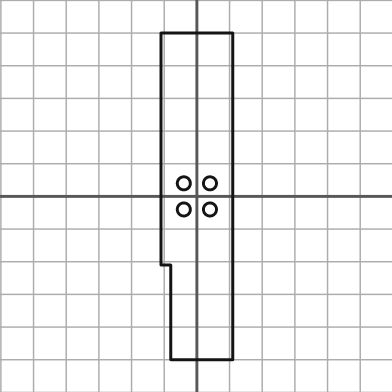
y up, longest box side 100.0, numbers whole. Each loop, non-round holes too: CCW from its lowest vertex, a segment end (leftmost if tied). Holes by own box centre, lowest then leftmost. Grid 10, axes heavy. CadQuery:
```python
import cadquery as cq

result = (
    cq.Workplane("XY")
    .moveTo(-8.0, -50.0)
    .lineTo(11.0, -50.0)
    .lineTo(11.0, 50.0)
    .lineTo(-11.0, 50.0)
    .lineTo(-11.0, -21.0)
    .lineTo(-8.0, -21.0)
    .close()
    .moveTo(-4.0, -4.0)
    .circle(2.0)
    .moveTo(4.0, -4.0)
    .circle(2.0)
    .moveTo(-4.0, 4.0)
    .circle(2.0)
    .moveTo(4.0, 4.0)
    .circle(2.0)
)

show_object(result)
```